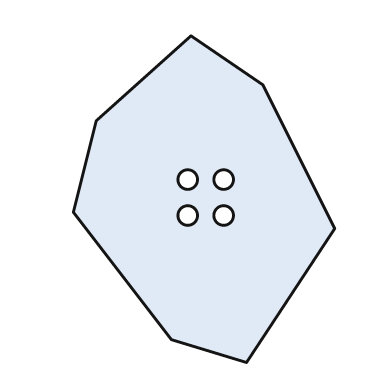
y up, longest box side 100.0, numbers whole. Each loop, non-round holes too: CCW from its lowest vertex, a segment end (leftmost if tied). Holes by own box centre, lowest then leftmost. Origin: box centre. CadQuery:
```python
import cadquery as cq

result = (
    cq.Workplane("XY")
    .moveTo(13.0, -50.0)
    .lineTo(40.0, -9.0)
    .lineTo(18.0, 35.0)
    .lineTo(-4.0, 50.0)
    .lineTo(-33.0, 24.0)
    .lineTo(-40.0, -4.0)
    .lineTo(-10.0, -43.0)
    .close()
    .moveTo(-5.0, -5.0)
    .circle(3.0)
    .moveTo(6.0, -5.0)
    .circle(3.0)
    .moveTo(-5.0, 6.0)
    .circle(3.0)
    .moveTo(6.0, 6.0)
    .circle(3.0)
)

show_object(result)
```